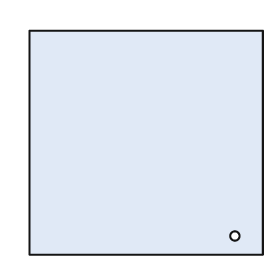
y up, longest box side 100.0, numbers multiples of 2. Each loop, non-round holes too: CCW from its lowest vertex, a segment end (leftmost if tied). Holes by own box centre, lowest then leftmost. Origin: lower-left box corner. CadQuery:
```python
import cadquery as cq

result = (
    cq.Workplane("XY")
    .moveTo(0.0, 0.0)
    .lineTo(100.0, 0.0)
    .lineTo(100.0, 96.0)
    .lineTo(0.0, 96.0)
    .close()
    .moveTo(88.0, 8.0)
    .circle(2.0)
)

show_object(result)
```